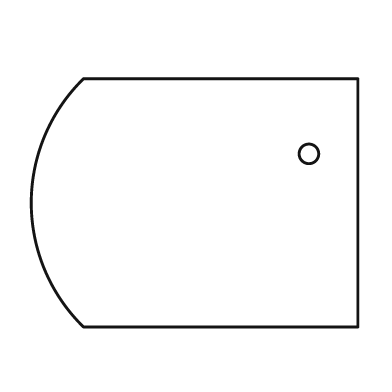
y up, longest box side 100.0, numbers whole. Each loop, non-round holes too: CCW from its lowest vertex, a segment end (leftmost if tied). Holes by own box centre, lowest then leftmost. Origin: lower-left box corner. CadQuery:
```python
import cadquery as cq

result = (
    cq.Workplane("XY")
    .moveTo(16.0, 0.0)
    .lineTo(100.0, 0.0)
    .lineTo(100.0, 76.0)
    .lineTo(16.0, 76.0)
    .threePointArc((0.0, 38.0), (16.0, 0.0))
    .close()
    .moveTo(85.0, 53.0)
    .circle(3.0)
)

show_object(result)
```